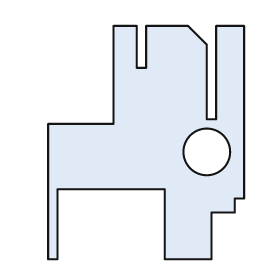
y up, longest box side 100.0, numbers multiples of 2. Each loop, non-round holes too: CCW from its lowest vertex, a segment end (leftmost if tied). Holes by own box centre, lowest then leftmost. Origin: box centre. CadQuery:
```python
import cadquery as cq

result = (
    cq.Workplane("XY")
    .moveTo(-42.0, -50.0)
    .lineTo(-38.0, -50.0)
    .lineTo(-38.0, -20.0)
    .lineTo(8.0, -20.0)
    .lineTo(8.0, -50.0)
    .lineTo(28.0, -50.0)
    .lineTo(28.0, -30.0)
    .lineTo(38.0, -30.0)
    .lineTo(38.0, -24.0)
    .lineTo(42.0, -24.0)
    .lineTo(42.0, 50.0)
    .lineTo(30.0, 50.0)
    .lineTo(30.0, 10.0)
    .lineTo(26.0, 10.0)
    .lineTo(26.0, 42.0)
    .lineTo(18.0, 50.0)
    .lineTo(0.0, 50.0)
    .lineTo(0.0, 32.0)
    .lineTo(-4.0, 32.0)
    .lineTo(-4.0, 50.0)
    .lineTo(-14.0, 50.0)
    .lineTo(-14.0, 8.0)
    .lineTo(-42.0, 8.0)
    .close()
    .moveTo(26.0, -4.0)
    .circle(10.0)
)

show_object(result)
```